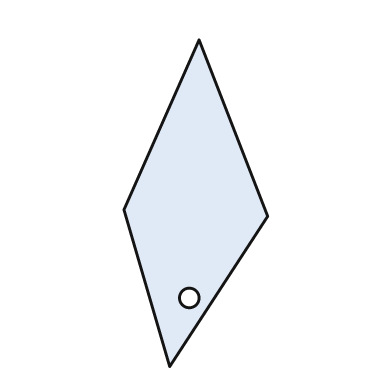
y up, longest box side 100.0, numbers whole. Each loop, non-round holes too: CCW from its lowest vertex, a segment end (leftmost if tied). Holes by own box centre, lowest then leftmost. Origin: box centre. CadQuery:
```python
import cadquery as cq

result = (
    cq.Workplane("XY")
    .moveTo(-8.0, -50.0)
    .lineTo(22.0, -4.0)
    .lineTo(1.0, 50.0)
    .lineTo(-22.0, -2.0)
    .close()
    .moveTo(-2.0, -29.0)
    .circle(3.0)
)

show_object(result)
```